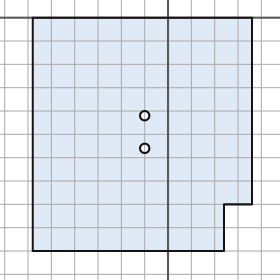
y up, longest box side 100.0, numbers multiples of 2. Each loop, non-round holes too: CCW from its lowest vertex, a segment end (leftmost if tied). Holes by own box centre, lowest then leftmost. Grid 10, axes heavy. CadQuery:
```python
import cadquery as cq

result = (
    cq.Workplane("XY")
    .moveTo(-58.0, -100.0)
    .lineTo(24.0, -100.0)
    .lineTo(24.0, -80.0)
    .lineTo(36.0, -80.0)
    .lineTo(36.0, 0.0)
    .lineTo(-58.0, 0.0)
    .close()
    .moveTo(-10.0, -56.0)
    .circle(2.0)
    .moveTo(-10.0, -42.0)
    .circle(2.0)
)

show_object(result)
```